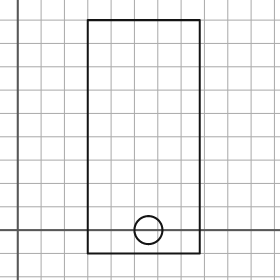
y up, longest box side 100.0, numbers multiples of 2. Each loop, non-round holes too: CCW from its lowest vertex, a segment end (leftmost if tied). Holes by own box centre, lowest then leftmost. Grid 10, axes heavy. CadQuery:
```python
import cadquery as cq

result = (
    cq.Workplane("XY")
    .moveTo(30.0, -10.0)
    .lineTo(78.0, -10.0)
    .lineTo(78.0, 90.0)
    .lineTo(30.0, 90.0)
    .close()
    .moveTo(56.0, 0.0)
    .circle(6.0)
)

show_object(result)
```